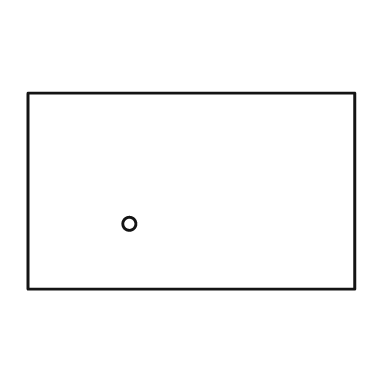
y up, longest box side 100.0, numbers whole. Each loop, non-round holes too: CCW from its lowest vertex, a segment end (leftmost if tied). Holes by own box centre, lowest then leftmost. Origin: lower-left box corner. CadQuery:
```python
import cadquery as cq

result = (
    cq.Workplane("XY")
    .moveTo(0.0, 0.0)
    .lineTo(100.0, 0.0)
    .lineTo(100.0, 60.0)
    .lineTo(0.0, 60.0)
    .close()
    .moveTo(31.0, 20.0)
    .circle(2.0)
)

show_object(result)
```